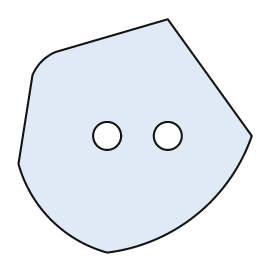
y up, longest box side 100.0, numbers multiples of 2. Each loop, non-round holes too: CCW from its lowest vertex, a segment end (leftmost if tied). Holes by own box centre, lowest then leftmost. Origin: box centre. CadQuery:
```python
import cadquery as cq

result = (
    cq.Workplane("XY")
    .moveTo(-12.0, -50.0)
    .threePointArc((26.0, -34.0), (50.0, 0.0))
    .lineTo(14.0, 50.0)
    .lineTo(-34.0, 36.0)
    .threePointArc((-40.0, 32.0), (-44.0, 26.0))
    .lineTo(-50.0, -12.0)
    .threePointArc((-36.0, -36.0), (-12.0, -50.0))
    .close()
    .moveTo(-12.0, 0.0)
    .circle(6.0)
    .moveTo(14.0, 0.0)
    .circle(6.0)
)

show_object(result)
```